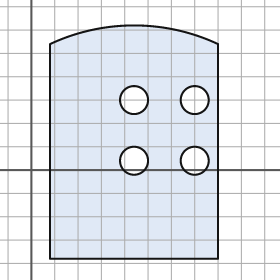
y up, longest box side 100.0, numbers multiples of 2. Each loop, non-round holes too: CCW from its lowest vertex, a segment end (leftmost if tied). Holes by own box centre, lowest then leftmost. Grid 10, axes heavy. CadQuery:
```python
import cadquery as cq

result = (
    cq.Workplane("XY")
    .moveTo(8.0, -38.0)
    .lineTo(80.0, -38.0)
    .lineTo(80.0, 54.0)
    .threePointArc((44.0, 62.0), (8.0, 54.0))
    .close()
    .moveTo(44.0, 4.0)
    .circle(6.0)
    .moveTo(70.0, 4.0)
    .circle(6.0)
    .moveTo(44.0, 30.0)
    .circle(6.0)
    .moveTo(70.0, 30.0)
    .circle(6.0)
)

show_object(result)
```